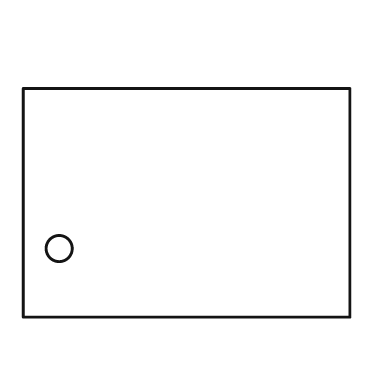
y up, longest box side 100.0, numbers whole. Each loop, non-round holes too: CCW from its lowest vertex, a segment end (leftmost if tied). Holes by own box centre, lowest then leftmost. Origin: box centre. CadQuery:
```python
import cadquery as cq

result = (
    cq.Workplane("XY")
    .moveTo(-50.0, -35.0)
    .lineTo(50.0, -35.0)
    .lineTo(50.0, 35.0)
    .lineTo(-50.0, 35.0)
    .close()
    .moveTo(-39.0, -14.0)
    .circle(4.0)
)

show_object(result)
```